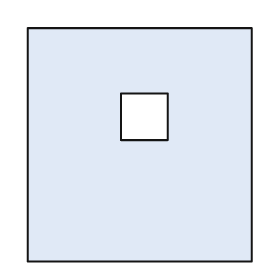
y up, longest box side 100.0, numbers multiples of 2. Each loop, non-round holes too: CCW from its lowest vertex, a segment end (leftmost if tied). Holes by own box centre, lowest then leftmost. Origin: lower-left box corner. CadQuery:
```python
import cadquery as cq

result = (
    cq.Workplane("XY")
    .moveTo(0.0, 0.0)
    .lineTo(96.0, 0.0)
    .lineTo(96.0, 100.0)
    .lineTo(0.0, 100.0)
    .close()
    .moveTo(40.0, 52.0)
    .lineTo(60.0, 52.0)
    .lineTo(60.0, 72.0)
    .lineTo(40.0, 72.0)
    .close()
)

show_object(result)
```